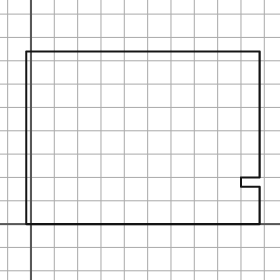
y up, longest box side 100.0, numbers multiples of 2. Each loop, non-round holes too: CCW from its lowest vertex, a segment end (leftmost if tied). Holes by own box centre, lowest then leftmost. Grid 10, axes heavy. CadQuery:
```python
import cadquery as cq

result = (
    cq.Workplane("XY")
    .moveTo(-2.0, 0.0)
    .lineTo(98.0, 0.0)
    .lineTo(98.0, 16.0)
    .lineTo(90.0, 16.0)
    .lineTo(90.0, 20.0)
    .lineTo(98.0, 20.0)
    .lineTo(98.0, 74.0)
    .lineTo(-2.0, 74.0)
    .close()
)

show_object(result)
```